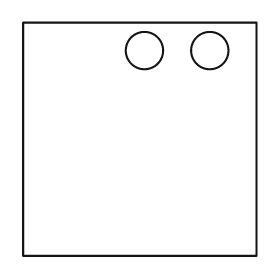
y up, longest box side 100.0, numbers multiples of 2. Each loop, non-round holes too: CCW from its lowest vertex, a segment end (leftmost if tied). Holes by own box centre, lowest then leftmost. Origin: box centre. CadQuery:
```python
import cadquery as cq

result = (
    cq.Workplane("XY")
    .moveTo(-50.0, -50.0)
    .lineTo(50.0, -50.0)
    .lineTo(50.0, 50.0)
    .lineTo(-50.0, 50.0)
    .close()
    .moveTo(2.0, 38.0)
    .circle(8.0)
    .moveTo(30.0, 38.0)
    .circle(8.0)
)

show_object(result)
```